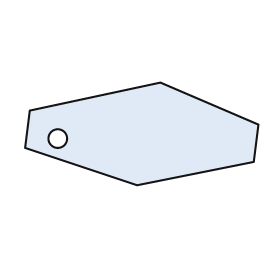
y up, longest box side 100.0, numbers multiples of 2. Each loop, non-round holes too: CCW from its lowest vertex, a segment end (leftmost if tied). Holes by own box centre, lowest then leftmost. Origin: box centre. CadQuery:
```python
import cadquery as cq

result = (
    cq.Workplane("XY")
    .moveTo(-2.0, -22.0)
    .lineTo(48.0, -12.0)
    .lineTo(50.0, 4.0)
    .lineTo(8.0, 22.0)
    .lineTo(-48.0, 10.0)
    .lineTo(-50.0, -6.0)
    .close()
    .moveTo(-36.0, -2.0)
    .circle(4.0)
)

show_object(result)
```